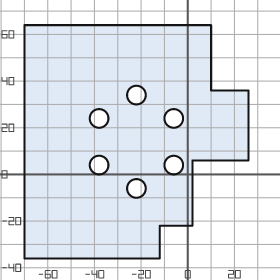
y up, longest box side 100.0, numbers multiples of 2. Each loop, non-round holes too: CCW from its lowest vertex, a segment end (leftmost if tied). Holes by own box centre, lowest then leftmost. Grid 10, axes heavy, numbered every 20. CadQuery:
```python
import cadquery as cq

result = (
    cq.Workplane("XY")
    .moveTo(-70.0, -36.0)
    .lineTo(-12.0, -36.0)
    .lineTo(-12.0, -22.0)
    .lineTo(2.0, -22.0)
    .lineTo(2.0, 6.0)
    .lineTo(26.0, 6.0)
    .lineTo(26.0, 36.0)
    .lineTo(10.0, 36.0)
    .lineTo(10.0, 64.0)
    .lineTo(-70.0, 64.0)
    .close()
    .moveTo(-22.0, -6.0)
    .circle(4.0)
    .moveTo(-38.0, 4.0)
    .circle(4.0)
    .moveTo(-6.0, 4.0)
    .circle(4.0)
    .moveTo(-38.0, 24.0)
    .circle(4.0)
    .moveTo(-6.0, 24.0)
    .circle(4.0)
    .moveTo(-22.0, 34.0)
    .circle(4.0)
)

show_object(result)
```